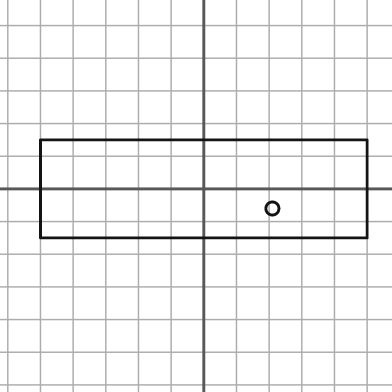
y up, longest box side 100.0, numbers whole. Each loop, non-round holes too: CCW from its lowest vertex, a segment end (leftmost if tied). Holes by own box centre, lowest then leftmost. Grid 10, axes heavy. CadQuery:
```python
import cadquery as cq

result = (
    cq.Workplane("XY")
    .moveTo(-50.0, -15.0)
    .lineTo(50.0, -15.0)
    .lineTo(50.0, 15.0)
    .lineTo(-50.0, 15.0)
    .close()
    .moveTo(21.0, -6.0)
    .circle(2.0)
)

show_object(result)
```